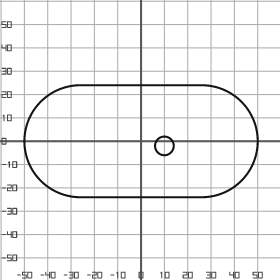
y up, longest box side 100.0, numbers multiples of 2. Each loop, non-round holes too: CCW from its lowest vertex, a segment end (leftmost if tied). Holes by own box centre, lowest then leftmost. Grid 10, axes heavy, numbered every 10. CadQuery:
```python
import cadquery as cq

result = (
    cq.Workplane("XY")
    .moveTo(-26.0, -24.0)
    .lineTo(26.0, -24.0)
    .threePointArc((50.0, 0.0), (26.0, 24.0))
    .lineTo(-26.0, 24.0)
    .threePointArc((-50.0, 0.0), (-26.0, -24.0))
    .close()
    .moveTo(10.0, -2.0)
    .circle(4.0)
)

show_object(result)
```